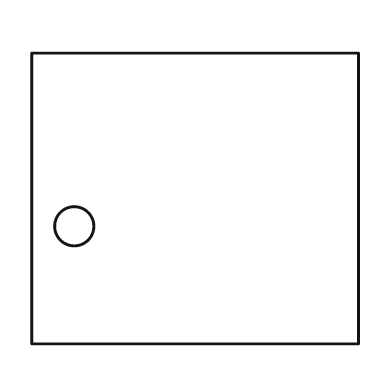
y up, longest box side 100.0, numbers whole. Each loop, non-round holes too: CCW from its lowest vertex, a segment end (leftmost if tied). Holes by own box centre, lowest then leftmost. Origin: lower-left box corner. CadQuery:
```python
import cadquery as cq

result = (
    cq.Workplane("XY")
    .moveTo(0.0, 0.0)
    .lineTo(100.0, 0.0)
    .lineTo(100.0, 89.0)
    .lineTo(0.0, 89.0)
    .close()
    .moveTo(13.0, 36.0)
    .circle(6.0)
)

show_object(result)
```